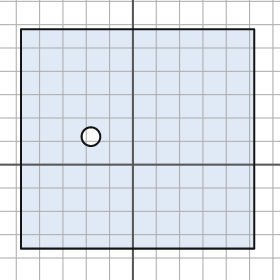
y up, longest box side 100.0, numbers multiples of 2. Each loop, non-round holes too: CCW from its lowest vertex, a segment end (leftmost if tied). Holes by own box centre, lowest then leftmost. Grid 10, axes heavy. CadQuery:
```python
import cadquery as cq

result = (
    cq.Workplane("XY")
    .moveTo(-48.0, -36.0)
    .lineTo(52.0, -36.0)
    .lineTo(52.0, 58.0)
    .lineTo(-48.0, 58.0)
    .close()
    .moveTo(-18.0, 12.0)
    .circle(4.0)
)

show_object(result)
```